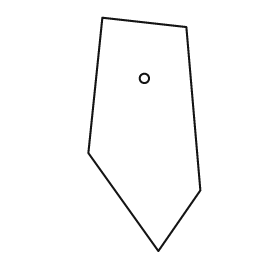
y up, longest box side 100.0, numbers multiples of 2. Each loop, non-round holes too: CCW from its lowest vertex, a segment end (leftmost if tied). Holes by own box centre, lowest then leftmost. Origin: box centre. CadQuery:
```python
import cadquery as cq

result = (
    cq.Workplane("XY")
    .moveTo(6.0, -50.0)
    .lineTo(24.0, -24.0)
    .lineTo(18.0, 46.0)
    .lineTo(-18.0, 50.0)
    .lineTo(-24.0, -8.0)
    .close()
    .moveTo(0.0, 24.0)
    .circle(2.0)
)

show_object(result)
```